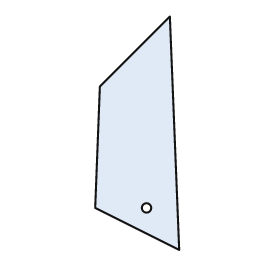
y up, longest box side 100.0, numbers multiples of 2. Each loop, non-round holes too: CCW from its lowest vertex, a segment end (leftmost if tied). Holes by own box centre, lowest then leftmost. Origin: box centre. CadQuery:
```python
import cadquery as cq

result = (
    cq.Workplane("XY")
    .moveTo(18.0, -50.0)
    .lineTo(14.0, 50.0)
    .lineTo(-16.0, 20.0)
    .lineTo(-18.0, -32.0)
    .close()
    .moveTo(4.0, -32.0)
    .circle(2.0)
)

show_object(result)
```